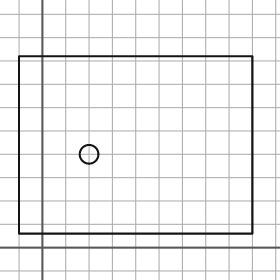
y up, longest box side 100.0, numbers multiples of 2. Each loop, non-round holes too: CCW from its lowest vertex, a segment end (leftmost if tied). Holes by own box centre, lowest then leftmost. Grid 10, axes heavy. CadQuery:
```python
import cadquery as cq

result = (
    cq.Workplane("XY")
    .moveTo(-10.0, 6.0)
    .lineTo(90.0, 6.0)
    .lineTo(90.0, 82.0)
    .lineTo(-10.0, 82.0)
    .close()
    .moveTo(20.0, 40.0)
    .circle(4.0)
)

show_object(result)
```